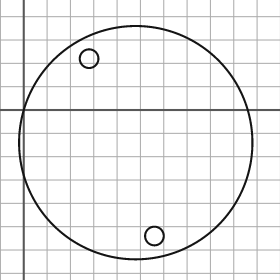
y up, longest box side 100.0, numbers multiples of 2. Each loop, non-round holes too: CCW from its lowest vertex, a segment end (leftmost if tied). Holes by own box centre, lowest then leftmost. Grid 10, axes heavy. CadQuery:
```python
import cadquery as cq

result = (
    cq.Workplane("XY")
    .moveTo(48.0, -14.0)
    .circle(50.0)
    .moveTo(56.0, -54.0)
    .circle(4.0)
    .moveTo(28.0, 22.0)
    .circle(4.0)
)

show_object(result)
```